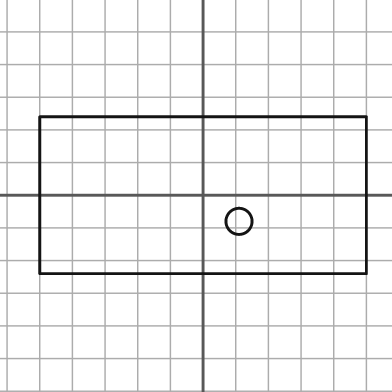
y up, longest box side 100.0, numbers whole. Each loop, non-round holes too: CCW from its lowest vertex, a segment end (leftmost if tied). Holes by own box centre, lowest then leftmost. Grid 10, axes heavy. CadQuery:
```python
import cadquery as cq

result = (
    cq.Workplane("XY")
    .moveTo(-50.0, -24.0)
    .lineTo(50.0, -24.0)
    .lineTo(50.0, 24.0)
    .lineTo(-50.0, 24.0)
    .close()
    .moveTo(11.0, -8.0)
    .circle(4.0)
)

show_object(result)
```